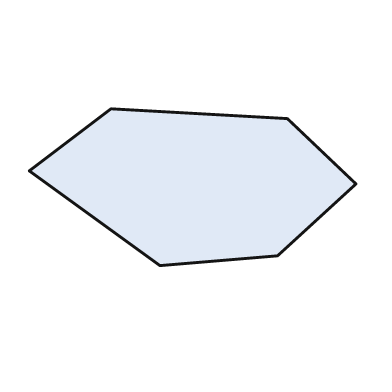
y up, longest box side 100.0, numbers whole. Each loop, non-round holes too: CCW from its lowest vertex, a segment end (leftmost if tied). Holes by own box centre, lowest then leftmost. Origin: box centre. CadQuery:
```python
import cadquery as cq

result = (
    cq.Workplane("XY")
    .moveTo(-10.0, -24.0)
    .lineTo(26.0, -21.0)
    .lineTo(50.0, 1.0)
    .lineTo(29.0, 21.0)
    .lineTo(-25.0, 24.0)
    .lineTo(-50.0, 5.0)
    .close()
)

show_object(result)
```